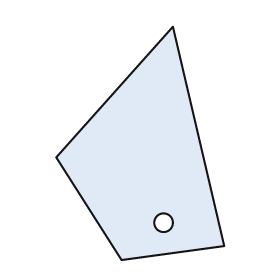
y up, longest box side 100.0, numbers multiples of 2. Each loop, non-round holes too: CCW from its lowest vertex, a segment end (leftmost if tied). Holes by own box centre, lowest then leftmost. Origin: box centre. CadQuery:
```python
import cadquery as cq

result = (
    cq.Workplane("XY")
    .moveTo(-8.0, -50.0)
    .lineTo(36.0, -44.0)
    .lineTo(14.0, 50.0)
    .lineTo(-36.0, -6.0)
    .close()
    .moveTo(10.0, -34.0)
    .circle(4.0)
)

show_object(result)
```